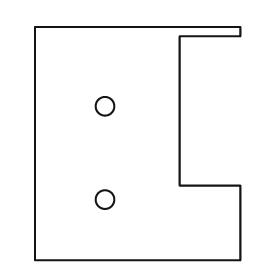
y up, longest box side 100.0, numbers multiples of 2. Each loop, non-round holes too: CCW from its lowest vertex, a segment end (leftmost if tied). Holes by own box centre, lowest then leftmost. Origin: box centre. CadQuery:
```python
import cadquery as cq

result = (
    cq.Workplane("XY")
    .moveTo(-44.0, -50.0)
    .lineTo(44.0, -50.0)
    .lineTo(44.0, -18.0)
    .lineTo(18.0, -18.0)
    .lineTo(18.0, 46.0)
    .lineTo(44.0, 46.0)
    .lineTo(44.0, 50.0)
    .lineTo(-44.0, 50.0)
    .close()
    .moveTo(-14.0, -24.0)
    .circle(4.0)
    .moveTo(-14.0, 16.0)
    .circle(4.0)
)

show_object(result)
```